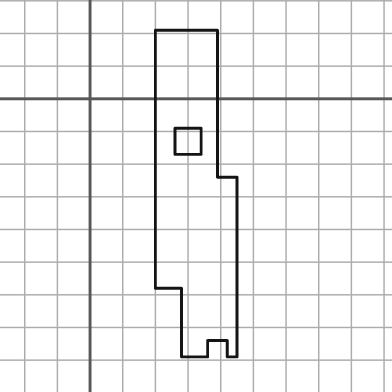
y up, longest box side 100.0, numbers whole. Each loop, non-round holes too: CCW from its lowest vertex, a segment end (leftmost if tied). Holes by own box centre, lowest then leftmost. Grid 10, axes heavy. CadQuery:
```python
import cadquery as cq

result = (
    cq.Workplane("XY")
    .moveTo(28.0, -79.0)
    .lineTo(36.0, -79.0)
    .lineTo(36.0, -74.0)
    .lineTo(42.0, -74.0)
    .lineTo(42.0, -79.0)
    .lineTo(45.0, -79.0)
    .lineTo(45.0, -24.0)
    .lineTo(39.0, -24.0)
    .lineTo(39.0, 21.0)
    .lineTo(20.0, 21.0)
    .lineTo(20.0, -58.0)
    .lineTo(28.0, -58.0)
    .close()
    .moveTo(26.0, -17.0)
    .lineTo(34.0, -17.0)
    .lineTo(34.0, -9.0)
    .lineTo(26.0, -9.0)
    .close()
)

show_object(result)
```